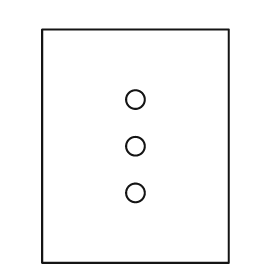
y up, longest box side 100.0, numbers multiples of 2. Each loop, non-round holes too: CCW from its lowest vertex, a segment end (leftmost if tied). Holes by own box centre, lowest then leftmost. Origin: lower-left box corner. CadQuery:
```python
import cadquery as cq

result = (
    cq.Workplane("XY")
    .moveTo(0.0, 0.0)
    .lineTo(80.0, 0.0)
    .lineTo(80.0, 100.0)
    .lineTo(0.0, 100.0)
    .close()
    .moveTo(40.0, 30.0)
    .circle(4.0)
    .moveTo(40.0, 50.0)
    .circle(4.0)
    .moveTo(40.0, 70.0)
    .circle(4.0)
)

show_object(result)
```